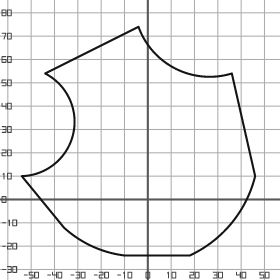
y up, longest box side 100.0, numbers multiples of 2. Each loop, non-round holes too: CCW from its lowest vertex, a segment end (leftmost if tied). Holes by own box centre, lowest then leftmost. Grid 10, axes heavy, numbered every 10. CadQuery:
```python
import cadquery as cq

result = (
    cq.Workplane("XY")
    .moveTo(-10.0, -24.0)
    .lineTo(18.0, -24.0)
    .threePointArc((36.0, -10.0), (46.0, 10.0))
    .lineTo(36.0, 54.0)
    .threePointArc((12.0, 56.0), (-4.0, 74.0))
    .lineTo(-44.0, 54.0)
    .threePointArc((-32.0, 28.0), (-54.0, 10.0))
    .lineTo(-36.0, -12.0)
    .threePointArc((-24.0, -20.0), (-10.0, -24.0))
    .close()
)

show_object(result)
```